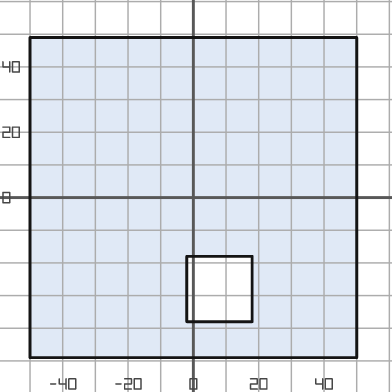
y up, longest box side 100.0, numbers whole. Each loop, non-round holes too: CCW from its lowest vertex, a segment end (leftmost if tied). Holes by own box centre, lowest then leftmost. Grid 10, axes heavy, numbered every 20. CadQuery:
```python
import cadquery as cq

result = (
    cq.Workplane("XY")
    .moveTo(-50.0, -49.0)
    .lineTo(50.0, -49.0)
    .lineTo(50.0, 49.0)
    .lineTo(-50.0, 49.0)
    .close()
    .moveTo(-2.0, -38.0)
    .lineTo(18.0, -38.0)
    .lineTo(18.0, -18.0)
    .lineTo(-2.0, -18.0)
    .close()
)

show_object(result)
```